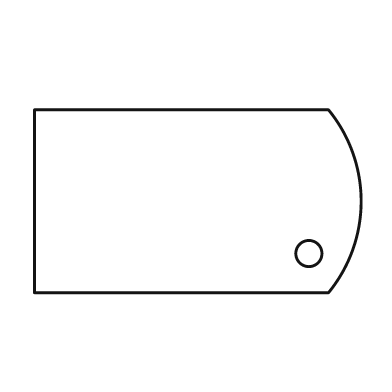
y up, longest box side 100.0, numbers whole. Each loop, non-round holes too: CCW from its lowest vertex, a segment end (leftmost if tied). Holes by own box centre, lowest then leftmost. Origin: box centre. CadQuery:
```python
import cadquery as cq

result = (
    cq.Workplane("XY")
    .moveTo(-50.0, -28.0)
    .lineTo(40.0, -28.0)
    .threePointArc((50.0, 0.0), (40.0, 28.0))
    .lineTo(-50.0, 28.0)
    .close()
    .moveTo(34.0, -16.0)
    .circle(4.0)
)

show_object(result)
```